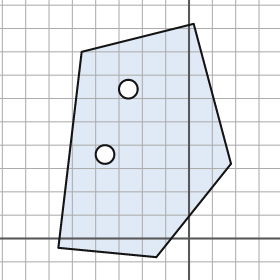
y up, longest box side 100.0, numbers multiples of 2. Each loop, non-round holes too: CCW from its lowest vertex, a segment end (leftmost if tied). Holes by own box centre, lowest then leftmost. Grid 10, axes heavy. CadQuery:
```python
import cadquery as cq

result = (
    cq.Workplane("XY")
    .moveTo(-14.0, -8.0)
    .lineTo(18.0, 32.0)
    .lineTo(2.0, 92.0)
    .lineTo(-46.0, 80.0)
    .lineTo(-56.0, -4.0)
    .close()
    .moveTo(-36.0, 36.0)
    .circle(4.0)
    .moveTo(-26.0, 64.0)
    .circle(4.0)
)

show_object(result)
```